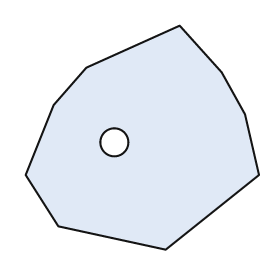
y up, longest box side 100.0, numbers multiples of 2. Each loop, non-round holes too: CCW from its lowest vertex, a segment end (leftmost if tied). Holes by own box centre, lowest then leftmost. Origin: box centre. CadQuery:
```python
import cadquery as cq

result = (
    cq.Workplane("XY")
    .moveTo(10.0, -48.0)
    .lineTo(50.0, -16.0)
    .lineTo(44.0, 10.0)
    .lineTo(34.0, 28.0)
    .lineTo(16.0, 48.0)
    .lineTo(-24.0, 30.0)
    .lineTo(-38.0, 14.0)
    .lineTo(-50.0, -16.0)
    .lineTo(-36.0, -38.0)
    .close()
    .moveTo(-12.0, -2.0)
    .circle(6.0)
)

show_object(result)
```